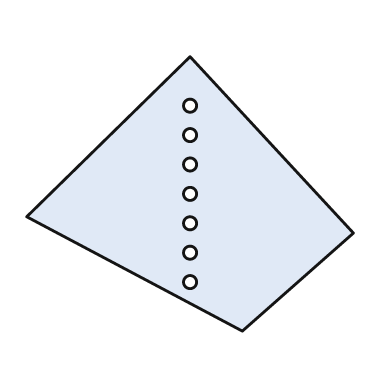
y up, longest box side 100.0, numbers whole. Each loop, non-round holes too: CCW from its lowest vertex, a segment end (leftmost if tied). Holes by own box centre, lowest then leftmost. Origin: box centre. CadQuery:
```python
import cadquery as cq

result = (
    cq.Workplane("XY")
    .moveTo(16.0, -42.0)
    .lineTo(50.0, -12.0)
    .lineTo(0.0, 42.0)
    .lineTo(-50.0, -7.0)
    .close()
    .moveTo(0.0, -27.0)
    .circle(2.0)
    .moveTo(0.0, -18.0)
    .circle(2.0)
    .moveTo(0.0, -9.0)
    .circle(2.0)
    .moveTo(0.0, 0.0)
    .circle(2.0)
    .moveTo(0.0, 9.0)
    .circle(2.0)
    .moveTo(0.0, 18.0)
    .circle(2.0)
    .moveTo(0.0, 27.0)
    .circle(2.0)
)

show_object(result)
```